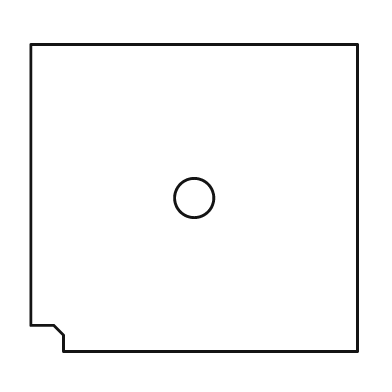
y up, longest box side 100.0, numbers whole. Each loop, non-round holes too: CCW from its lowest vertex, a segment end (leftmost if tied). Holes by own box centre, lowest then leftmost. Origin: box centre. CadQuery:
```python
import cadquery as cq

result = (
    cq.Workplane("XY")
    .moveTo(-40.0, -47.0)
    .lineTo(50.0, -47.0)
    .lineTo(50.0, 47.0)
    .lineTo(-50.0, 47.0)
    .lineTo(-50.0, -39.0)
    .lineTo(-43.0, -39.0)
    .lineTo(-40.0, -42.0)
    .close()
    .moveTo(0.0, 0.0)
    .circle(6.0)
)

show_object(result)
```